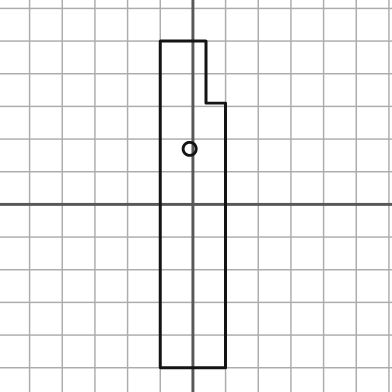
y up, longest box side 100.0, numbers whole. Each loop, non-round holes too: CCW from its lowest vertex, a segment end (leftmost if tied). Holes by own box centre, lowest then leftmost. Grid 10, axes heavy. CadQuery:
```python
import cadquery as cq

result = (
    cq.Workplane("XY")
    .moveTo(-10.0, -50.0)
    .lineTo(10.0, -50.0)
    .lineTo(10.0, 31.0)
    .lineTo(4.0, 31.0)
    .lineTo(4.0, 50.0)
    .lineTo(-10.0, 50.0)
    .close()
    .moveTo(-1.0, 17.0)
    .circle(2.0)
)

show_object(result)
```